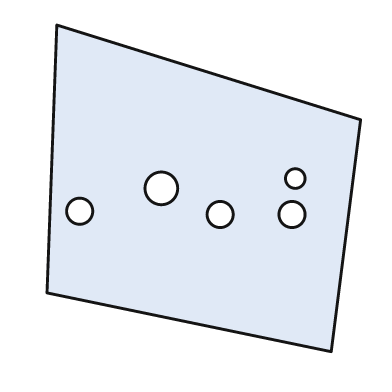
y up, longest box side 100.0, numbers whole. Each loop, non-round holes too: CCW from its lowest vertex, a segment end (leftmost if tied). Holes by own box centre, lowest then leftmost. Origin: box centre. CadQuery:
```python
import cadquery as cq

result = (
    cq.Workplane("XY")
    .moveTo(39.0, -50.0)
    .lineTo(48.0, 21.0)
    .lineTo(-45.0, 50.0)
    .lineTo(-48.0, -32.0)
    .close()
    .moveTo(5.0, -8.0)
    .circle(4.0)
    .moveTo(27.0, -8.0)
    .circle(4.0)
    .moveTo(-38.0, -7.0)
    .circle(4.0)
    .moveTo(-13.0, 0.0)
    .circle(5.0)
    .moveTo(28.0, 3.0)
    .circle(3.0)
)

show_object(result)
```